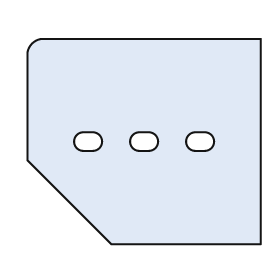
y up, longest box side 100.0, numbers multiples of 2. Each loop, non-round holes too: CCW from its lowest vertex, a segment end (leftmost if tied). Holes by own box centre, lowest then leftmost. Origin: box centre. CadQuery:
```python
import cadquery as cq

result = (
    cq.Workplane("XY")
    .moveTo(-14.0, -44.0)
    .lineTo(50.0, -44.0)
    .lineTo(50.0, 44.0)
    .lineTo(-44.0, 44.0)
    .threePointArc((-48.0, 42.0), (-50.0, 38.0))
    .lineTo(-50.0, -8.0)
    .close()
    .moveTo(-26.0, -4.0)
    .lineTo(-22.0, -4.0)
    .threePointArc((-18.0, 0.0), (-22.0, 4.0))
    .lineTo(-26.0, 4.0)
    .threePointArc((-30.0, 0.0), (-26.0, -4.0))
    .close()
    .moveTo(-2.0, -4.0)
    .lineTo(2.0, -4.0)
    .threePointArc((6.0, 0.0), (2.0, 4.0))
    .lineTo(-2.0, 4.0)
    .threePointArc((-6.0, 0.0), (-2.0, -4.0))
    .close()
    .moveTo(22.0, -4.0)
    .lineTo(26.0, -4.0)
    .threePointArc((30.0, 0.0), (26.0, 4.0))
    .lineTo(22.0, 4.0)
    .threePointArc((18.0, 0.0), (22.0, -4.0))
    .close()
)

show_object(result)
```